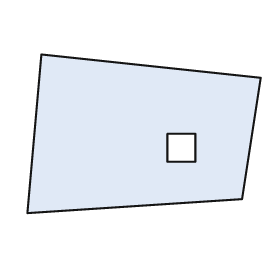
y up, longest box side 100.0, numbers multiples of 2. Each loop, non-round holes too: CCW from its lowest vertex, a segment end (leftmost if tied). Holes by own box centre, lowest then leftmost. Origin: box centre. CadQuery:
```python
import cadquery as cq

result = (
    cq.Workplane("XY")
    .moveTo(-50.0, -34.0)
    .lineTo(42.0, -28.0)
    .lineTo(50.0, 24.0)
    .lineTo(-44.0, 34.0)
    .close()
    .moveTo(10.0, -12.0)
    .lineTo(22.0, -12.0)
    .lineTo(22.0, 0.0)
    .lineTo(10.0, 0.0)
    .close()
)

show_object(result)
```